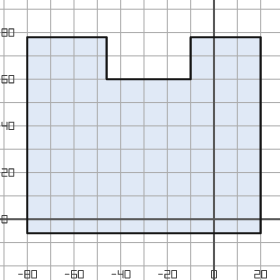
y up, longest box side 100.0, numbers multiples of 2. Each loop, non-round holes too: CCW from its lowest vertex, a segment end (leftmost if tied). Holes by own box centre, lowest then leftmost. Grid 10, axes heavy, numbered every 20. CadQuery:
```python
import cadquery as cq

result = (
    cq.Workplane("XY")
    .moveTo(-80.0, -6.0)
    .lineTo(20.0, -6.0)
    .lineTo(20.0, 78.0)
    .lineTo(-10.0, 78.0)
    .lineTo(-10.0, 60.0)
    .lineTo(-46.0, 60.0)
    .lineTo(-46.0, 78.0)
    .lineTo(-80.0, 78.0)
    .close()
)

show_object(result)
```